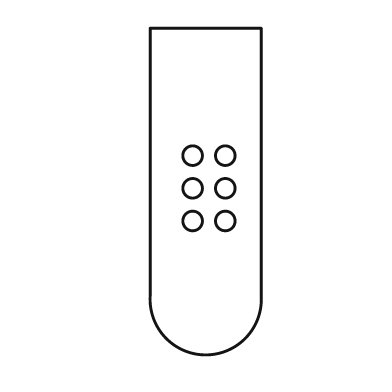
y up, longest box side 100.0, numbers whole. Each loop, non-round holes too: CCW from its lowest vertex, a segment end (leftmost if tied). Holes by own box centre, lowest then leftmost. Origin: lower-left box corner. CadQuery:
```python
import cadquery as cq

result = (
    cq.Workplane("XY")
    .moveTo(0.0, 18.0)
    .threePointArc((17.0, 0.0), (34.0, 18.0))
    .lineTo(34.0, 100.0)
    .lineTo(0.0, 100.0)
    .close()
    .moveTo(13.0, 41.0)
    .circle(3.0)
    .moveTo(23.0, 41.0)
    .circle(3.0)
    .moveTo(13.0, 51.0)
    .circle(3.0)
    .moveTo(23.0, 51.0)
    .circle(3.0)
    .moveTo(13.0, 61.0)
    .circle(3.0)
    .moveTo(23.0, 61.0)
    .circle(3.0)
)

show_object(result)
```